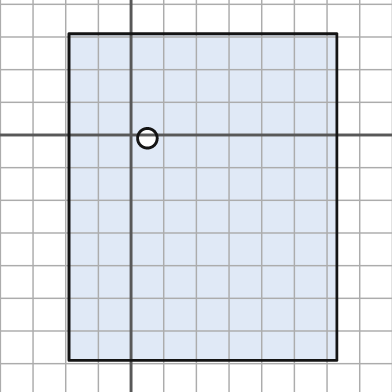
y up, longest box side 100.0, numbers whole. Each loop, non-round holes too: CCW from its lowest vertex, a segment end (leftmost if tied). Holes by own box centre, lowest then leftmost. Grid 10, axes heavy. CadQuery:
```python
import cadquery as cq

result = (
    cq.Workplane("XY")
    .moveTo(-19.0, -69.0)
    .lineTo(63.0, -69.0)
    .lineTo(63.0, 31.0)
    .lineTo(-19.0, 31.0)
    .close()
    .moveTo(5.0, -1.0)
    .circle(3.0)
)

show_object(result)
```